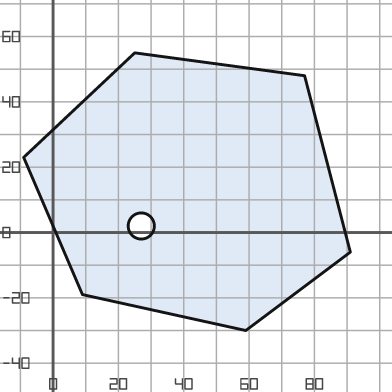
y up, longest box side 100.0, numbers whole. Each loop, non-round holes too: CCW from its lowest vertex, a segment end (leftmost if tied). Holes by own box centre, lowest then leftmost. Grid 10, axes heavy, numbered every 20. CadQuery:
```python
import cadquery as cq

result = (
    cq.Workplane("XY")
    .moveTo(59.0, -30.0)
    .lineTo(91.0, -6.0)
    .lineTo(77.0, 48.0)
    .lineTo(25.0, 55.0)
    .lineTo(-9.0, 23.0)
    .lineTo(9.0, -19.0)
    .close()
    .moveTo(27.0, 2.0)
    .circle(4.0)
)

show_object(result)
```